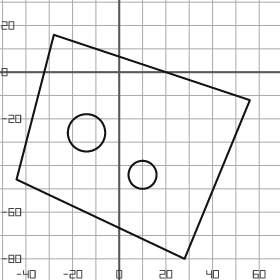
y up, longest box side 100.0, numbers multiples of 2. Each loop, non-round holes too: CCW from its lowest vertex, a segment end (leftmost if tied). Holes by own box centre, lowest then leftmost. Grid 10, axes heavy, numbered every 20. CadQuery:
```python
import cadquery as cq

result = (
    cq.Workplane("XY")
    .moveTo(28.0, -80.0)
    .lineTo(56.0, -12.0)
    .lineTo(-28.0, 16.0)
    .lineTo(-44.0, -46.0)
    .close()
    .moveTo(10.0, -44.0)
    .circle(6.0)
    .moveTo(-14.0, -26.0)
    .circle(8.0)
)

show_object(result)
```